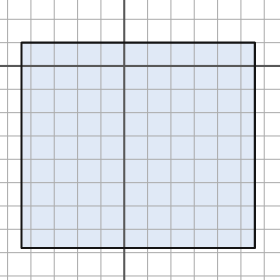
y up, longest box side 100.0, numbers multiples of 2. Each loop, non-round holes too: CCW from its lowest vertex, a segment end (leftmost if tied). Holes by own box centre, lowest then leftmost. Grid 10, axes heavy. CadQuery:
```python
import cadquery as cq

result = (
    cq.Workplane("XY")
    .moveTo(-44.0, -78.0)
    .lineTo(56.0, -78.0)
    .lineTo(56.0, 10.0)
    .lineTo(-44.0, 10.0)
    .close()
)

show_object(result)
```